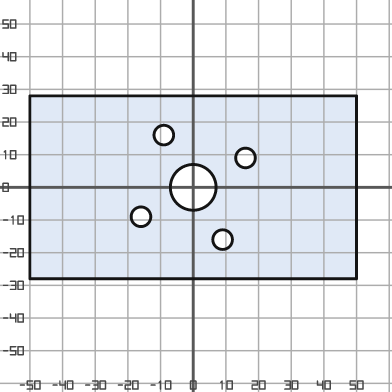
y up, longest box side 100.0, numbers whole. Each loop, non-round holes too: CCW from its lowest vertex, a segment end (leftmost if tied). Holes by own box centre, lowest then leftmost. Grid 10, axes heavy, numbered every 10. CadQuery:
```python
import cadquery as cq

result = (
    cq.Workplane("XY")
    .moveTo(-50.0, -28.0)
    .lineTo(50.0, -28.0)
    .lineTo(50.0, 28.0)
    .lineTo(-50.0, 28.0)
    .close()
    .moveTo(9.0, -16.0)
    .circle(3.0)
    .moveTo(-16.0, -9.0)
    .circle(3.0)
    .moveTo(0.0, 0.0)
    .circle(7.0)
    .moveTo(16.0, 9.0)
    .circle(3.0)
    .moveTo(-9.0, 16.0)
    .circle(3.0)
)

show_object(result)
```